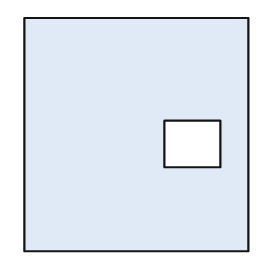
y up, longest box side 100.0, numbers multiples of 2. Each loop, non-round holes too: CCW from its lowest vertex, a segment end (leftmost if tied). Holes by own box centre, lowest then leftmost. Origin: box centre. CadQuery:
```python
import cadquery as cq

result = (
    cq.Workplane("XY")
    .moveTo(-48.0, -50.0)
    .lineTo(48.0, -50.0)
    .lineTo(48.0, 50.0)
    .lineTo(-48.0, 50.0)
    .close()
    .moveTo(12.0, -14.0)
    .lineTo(36.0, -14.0)
    .lineTo(36.0, 6.0)
    .lineTo(12.0, 6.0)
    .close()
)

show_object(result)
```